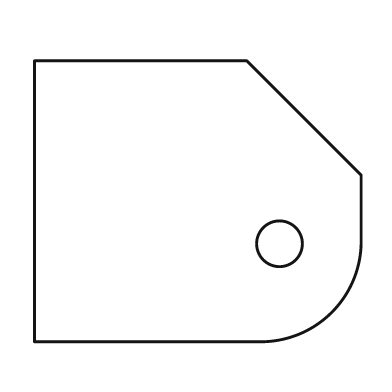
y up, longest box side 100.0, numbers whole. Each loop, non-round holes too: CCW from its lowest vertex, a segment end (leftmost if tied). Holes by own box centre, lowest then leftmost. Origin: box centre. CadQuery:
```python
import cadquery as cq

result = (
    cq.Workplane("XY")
    .moveTo(-50.0, -43.0)
    .lineTo(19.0, -43.0)
    .threePointArc((41.0, -34.0), (50.0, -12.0))
    .lineTo(50.0, 8.0)
    .lineTo(15.0, 43.0)
    .lineTo(-50.0, 43.0)
    .close()
    .moveTo(25.0, -13.0)
    .circle(7.0)
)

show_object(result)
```